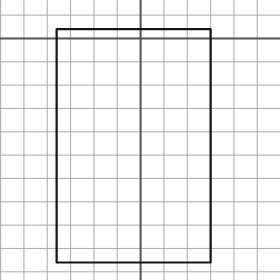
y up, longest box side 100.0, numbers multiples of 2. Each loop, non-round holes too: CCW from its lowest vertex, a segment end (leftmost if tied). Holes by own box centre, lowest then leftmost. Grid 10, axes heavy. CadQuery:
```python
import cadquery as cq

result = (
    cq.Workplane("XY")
    .moveTo(-36.0, -96.0)
    .lineTo(30.0, -96.0)
    .lineTo(30.0, 4.0)
    .lineTo(-36.0, 4.0)
    .close()
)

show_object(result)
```